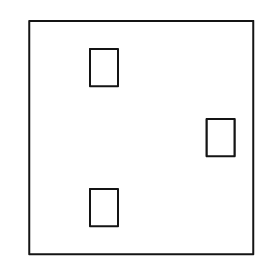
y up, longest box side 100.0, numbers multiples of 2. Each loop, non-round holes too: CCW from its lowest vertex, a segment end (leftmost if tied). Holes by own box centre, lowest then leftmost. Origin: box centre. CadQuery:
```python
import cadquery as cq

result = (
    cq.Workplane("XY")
    .moveTo(-48.0, -50.0)
    .lineTo(48.0, -50.0)
    .lineTo(48.0, 50.0)
    .lineTo(-48.0, 50.0)
    .close()
    .moveTo(-22.0, -38.0)
    .lineTo(-10.0, -38.0)
    .lineTo(-10.0, -22.0)
    .lineTo(-22.0, -22.0)
    .close()
    .moveTo(28.0, -8.0)
    .lineTo(40.0, -8.0)
    .lineTo(40.0, 8.0)
    .lineTo(28.0, 8.0)
    .close()
    .moveTo(-22.0, 22.0)
    .lineTo(-10.0, 22.0)
    .lineTo(-10.0, 38.0)
    .lineTo(-22.0, 38.0)
    .close()
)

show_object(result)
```